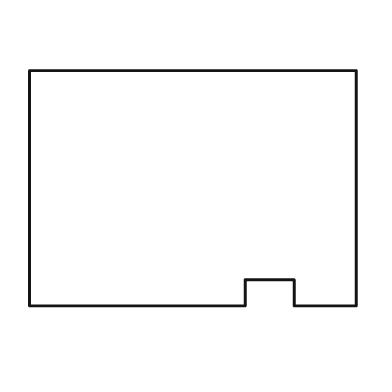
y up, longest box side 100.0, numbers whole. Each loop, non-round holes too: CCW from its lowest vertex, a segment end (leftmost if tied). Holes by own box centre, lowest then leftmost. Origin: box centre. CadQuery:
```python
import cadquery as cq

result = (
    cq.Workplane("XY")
    .moveTo(-50.0, -36.0)
    .lineTo(16.0, -36.0)
    .lineTo(16.0, -28.0)
    .lineTo(31.0, -28.0)
    .lineTo(31.0, -36.0)
    .lineTo(50.0, -36.0)
    .lineTo(50.0, 36.0)
    .lineTo(-50.0, 36.0)
    .close()
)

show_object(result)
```